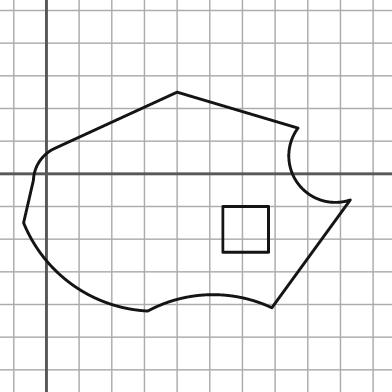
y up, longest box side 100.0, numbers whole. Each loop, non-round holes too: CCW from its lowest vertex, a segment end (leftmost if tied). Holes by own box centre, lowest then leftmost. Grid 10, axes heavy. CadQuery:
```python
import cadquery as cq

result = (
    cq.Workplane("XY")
    .moveTo(31.0, -42.0)
    .threePointArc((50.0, -37.0), (69.0, -41.0))
    .lineTo(93.0, -8.0)
    .threePointArc((77.0, -3.0), (77.0, 14.0))
    .lineTo(40.0, 25.0)
    .lineTo(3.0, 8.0)
    .threePointArc((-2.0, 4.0), (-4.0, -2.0))
    .lineTo(-7.0, -15.0)
    .threePointArc((8.0, -34.0), (31.0, -42.0))
    .close()
    .moveTo(54.0, -24.0)
    .lineTo(68.0, -24.0)
    .lineTo(68.0, -10.0)
    .lineTo(54.0, -10.0)
    .close()
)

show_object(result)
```